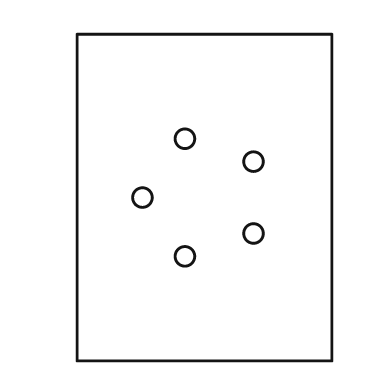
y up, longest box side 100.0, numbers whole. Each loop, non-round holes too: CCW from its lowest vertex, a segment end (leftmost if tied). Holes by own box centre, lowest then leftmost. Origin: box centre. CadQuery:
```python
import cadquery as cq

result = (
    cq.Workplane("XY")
    .moveTo(-39.0, -50.0)
    .lineTo(39.0, -50.0)
    .lineTo(39.0, 50.0)
    .lineTo(-39.0, 50.0)
    .close()
    .moveTo(-6.0, -18.0)
    .circle(3.0)
    .moveTo(15.0, -11.0)
    .circle(3.0)
    .moveTo(-19.0, 0.0)
    .circle(3.0)
    .moveTo(15.0, 11.0)
    .circle(3.0)
    .moveTo(-6.0, 18.0)
    .circle(3.0)
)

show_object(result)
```